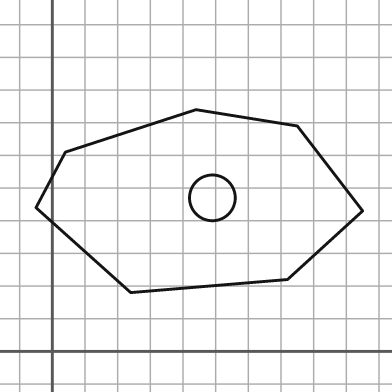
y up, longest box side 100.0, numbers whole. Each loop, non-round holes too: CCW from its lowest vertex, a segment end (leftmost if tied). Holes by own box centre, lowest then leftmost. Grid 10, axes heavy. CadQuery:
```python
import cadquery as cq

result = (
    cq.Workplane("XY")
    .moveTo(24.0, 18.0)
    .lineTo(72.0, 22.0)
    .lineTo(95.0, 43.0)
    .lineTo(75.0, 69.0)
    .lineTo(44.0, 74.0)
    .lineTo(4.0, 61.0)
    .lineTo(-5.0, 44.0)
    .close()
    .moveTo(49.0, 47.0)
    .circle(7.0)
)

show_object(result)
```